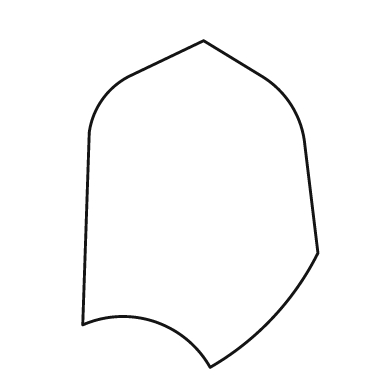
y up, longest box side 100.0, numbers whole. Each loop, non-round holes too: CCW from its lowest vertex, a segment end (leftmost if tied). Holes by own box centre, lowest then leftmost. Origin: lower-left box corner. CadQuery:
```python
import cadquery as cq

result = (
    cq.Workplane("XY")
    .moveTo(39.0, 0.0)
    .threePointArc((58.0, 15.0), (72.0, 35.0))
    .lineTo(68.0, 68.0)
    .threePointArc((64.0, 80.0), (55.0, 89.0))
    .lineTo(37.0, 100.0)
    .lineTo(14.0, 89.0)
    .threePointArc((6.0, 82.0), (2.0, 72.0))
    .lineTo(0.0, 13.0)
    .threePointArc((22.0, 14.0), (39.0, 0.0))
    .close()
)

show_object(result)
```